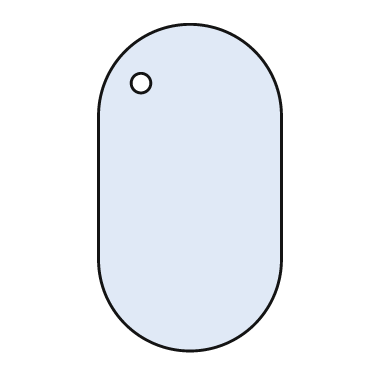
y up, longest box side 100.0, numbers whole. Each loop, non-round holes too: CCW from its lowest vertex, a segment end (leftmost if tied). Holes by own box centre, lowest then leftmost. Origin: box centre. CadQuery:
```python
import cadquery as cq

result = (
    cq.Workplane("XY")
    .moveTo(-28.0, -22.0)
    .threePointArc((0.0, -50.0), (28.0, -22.0))
    .lineTo(28.0, 22.0)
    .threePointArc((0.0, 50.0), (-28.0, 22.0))
    .close()
    .moveTo(-15.0, 32.0)
    .circle(3.0)
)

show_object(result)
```